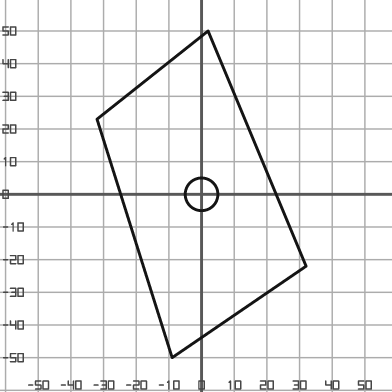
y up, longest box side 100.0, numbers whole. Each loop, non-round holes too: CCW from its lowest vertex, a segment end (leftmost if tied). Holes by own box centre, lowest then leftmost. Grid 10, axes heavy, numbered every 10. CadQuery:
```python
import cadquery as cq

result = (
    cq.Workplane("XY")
    .moveTo(-9.0, -50.0)
    .lineTo(32.0, -22.0)
    .lineTo(2.0, 50.0)
    .lineTo(-32.0, 23.0)
    .close()
    .moveTo(0.0, 0.0)
    .circle(5.0)
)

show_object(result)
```